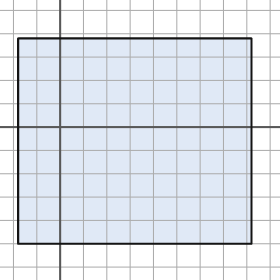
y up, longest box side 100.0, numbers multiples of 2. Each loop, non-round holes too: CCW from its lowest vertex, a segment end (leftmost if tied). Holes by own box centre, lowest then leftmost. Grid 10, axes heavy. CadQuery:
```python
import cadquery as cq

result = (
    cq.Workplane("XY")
    .moveTo(-18.0, -50.0)
    .lineTo(82.0, -50.0)
    .lineTo(82.0, 38.0)
    .lineTo(-18.0, 38.0)
    .close()
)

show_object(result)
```